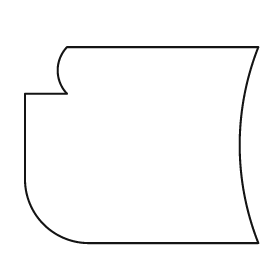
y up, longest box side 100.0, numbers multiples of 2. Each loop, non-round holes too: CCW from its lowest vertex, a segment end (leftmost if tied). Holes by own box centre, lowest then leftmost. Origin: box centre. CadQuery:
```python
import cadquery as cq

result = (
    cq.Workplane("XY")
    .moveTo(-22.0, -42.0)
    .lineTo(50.0, -42.0)
    .threePointArc((42.0, 0.0), (50.0, 42.0))
    .lineTo(-32.0, 42.0)
    .threePointArc((-36.0, 32.0), (-32.0, 22.0))
    .lineTo(-50.0, 22.0)
    .lineTo(-50.0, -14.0)
    .threePointArc((-42.0, -34.0), (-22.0, -42.0))
    .close()
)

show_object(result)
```